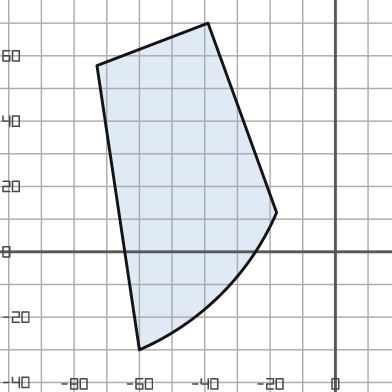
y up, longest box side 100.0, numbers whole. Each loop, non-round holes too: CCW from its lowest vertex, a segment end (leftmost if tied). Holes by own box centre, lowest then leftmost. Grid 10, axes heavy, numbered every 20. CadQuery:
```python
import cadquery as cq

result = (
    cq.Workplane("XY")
    .moveTo(-60.0, -30.0)
    .threePointArc((-35.0, -13.0), (-18.0, 12.0))
    .lineTo(-39.0, 70.0)
    .lineTo(-73.0, 57.0)
    .close()
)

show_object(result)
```